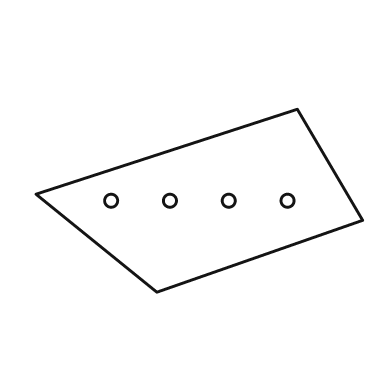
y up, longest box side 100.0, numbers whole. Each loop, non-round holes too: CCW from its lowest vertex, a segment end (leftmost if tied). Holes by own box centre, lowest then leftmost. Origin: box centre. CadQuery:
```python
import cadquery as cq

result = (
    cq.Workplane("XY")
    .moveTo(-13.0, -28.0)
    .lineTo(50.0, -6.0)
    .lineTo(30.0, 28.0)
    .lineTo(-50.0, 2.0)
    .close()
    .moveTo(-27.0, 0.0)
    .circle(2.0)
    .moveTo(-9.0, 0.0)
    .circle(2.0)
    .moveTo(9.0, 0.0)
    .circle(2.0)
    .moveTo(27.0, 0.0)
    .circle(2.0)
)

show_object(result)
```